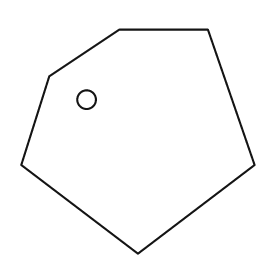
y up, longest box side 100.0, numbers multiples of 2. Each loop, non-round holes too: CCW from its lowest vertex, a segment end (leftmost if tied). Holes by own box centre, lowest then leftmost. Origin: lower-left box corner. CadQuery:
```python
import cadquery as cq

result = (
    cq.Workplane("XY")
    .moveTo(50.0, 0.0)
    .lineTo(100.0, 38.0)
    .lineTo(80.0, 96.0)
    .lineTo(42.0, 96.0)
    .lineTo(12.0, 76.0)
    .lineTo(0.0, 38.0)
    .close()
    .moveTo(28.0, 66.0)
    .circle(4.0)
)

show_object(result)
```